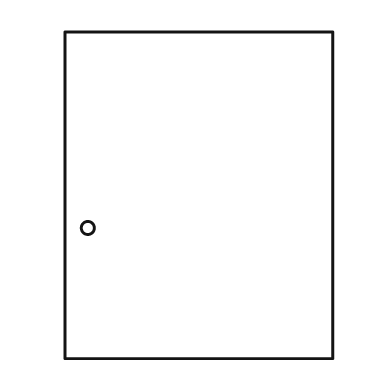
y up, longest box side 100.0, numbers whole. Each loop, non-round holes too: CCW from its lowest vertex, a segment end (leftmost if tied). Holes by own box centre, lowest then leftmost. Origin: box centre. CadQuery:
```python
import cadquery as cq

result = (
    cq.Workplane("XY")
    .moveTo(-41.0, -50.0)
    .lineTo(41.0, -50.0)
    .lineTo(41.0, 50.0)
    .lineTo(-41.0, 50.0)
    .close()
    .moveTo(-34.0, -10.0)
    .circle(2.0)
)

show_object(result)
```